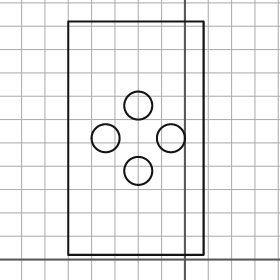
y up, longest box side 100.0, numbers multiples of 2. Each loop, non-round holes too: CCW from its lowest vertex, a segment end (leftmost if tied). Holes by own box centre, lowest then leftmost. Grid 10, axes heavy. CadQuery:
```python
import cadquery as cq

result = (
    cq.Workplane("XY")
    .moveTo(-50.0, 2.0)
    .lineTo(8.0, 2.0)
    .lineTo(8.0, 102.0)
    .lineTo(-50.0, 102.0)
    .close()
    .moveTo(-20.0, 38.0)
    .circle(6.0)
    .moveTo(-34.0, 52.0)
    .circle(6.0)
    .moveTo(-6.0, 52.0)
    .circle(6.0)
    .moveTo(-20.0, 66.0)
    .circle(6.0)
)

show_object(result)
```